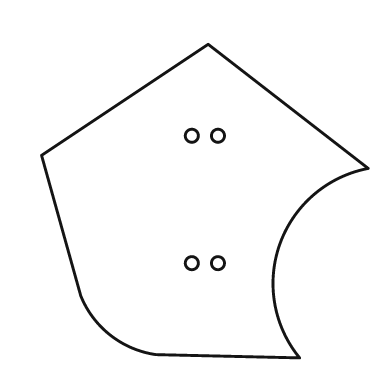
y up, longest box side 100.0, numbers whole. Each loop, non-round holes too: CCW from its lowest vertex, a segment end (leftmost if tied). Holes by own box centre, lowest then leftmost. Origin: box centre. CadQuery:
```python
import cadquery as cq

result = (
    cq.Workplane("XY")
    .moveTo(29.0, -48.0)
    .threePointArc((23.0, -13.0), (50.0, 10.0))
    .lineTo(1.0, 48.0)
    .lineTo(-50.0, 14.0)
    .lineTo(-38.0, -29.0)
    .threePointArc((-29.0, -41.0), (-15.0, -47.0))
    .close()
    .moveTo(-4.0, -19.0)
    .circle(2.0)
    .moveTo(4.0, -19.0)
    .circle(2.0)
    .moveTo(-4.0, 20.0)
    .circle(2.0)
    .moveTo(4.0, 20.0)
    .circle(2.0)
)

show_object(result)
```